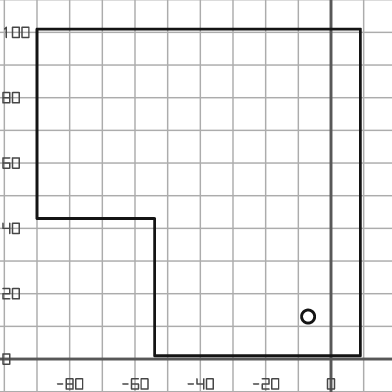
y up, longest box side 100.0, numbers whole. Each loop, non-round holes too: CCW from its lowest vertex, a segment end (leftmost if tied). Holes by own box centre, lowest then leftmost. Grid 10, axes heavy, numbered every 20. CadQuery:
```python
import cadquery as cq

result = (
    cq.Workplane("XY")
    .moveTo(-54.0, 1.0)
    .lineTo(9.0, 1.0)
    .lineTo(9.0, 101.0)
    .lineTo(-90.0, 101.0)
    .lineTo(-90.0, 43.0)
    .lineTo(-54.0, 43.0)
    .close()
    .moveTo(-7.0, 13.0)
    .circle(2.0)
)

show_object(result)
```